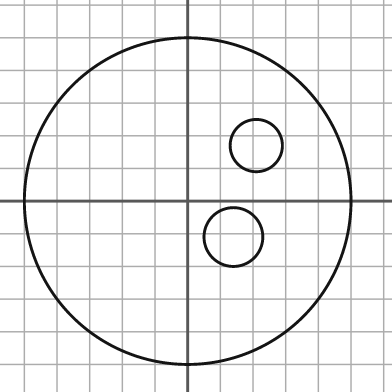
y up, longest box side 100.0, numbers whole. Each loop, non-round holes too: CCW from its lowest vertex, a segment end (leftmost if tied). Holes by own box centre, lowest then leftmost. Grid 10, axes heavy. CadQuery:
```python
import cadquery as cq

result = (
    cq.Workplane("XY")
    .moveTo(0.0, 0.0)
    .circle(50.0)
    .moveTo(14.0, -11.0)
    .circle(9.0)
    .moveTo(21.0, 17.0)
    .circle(8.0)
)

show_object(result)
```